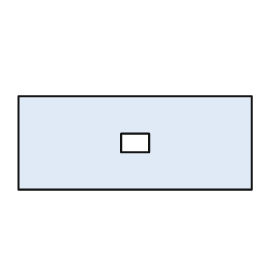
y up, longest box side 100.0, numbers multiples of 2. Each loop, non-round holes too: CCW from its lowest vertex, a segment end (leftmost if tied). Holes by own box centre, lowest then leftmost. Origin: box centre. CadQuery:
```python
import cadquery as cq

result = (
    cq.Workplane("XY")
    .moveTo(-50.0, -20.0)
    .lineTo(50.0, -20.0)
    .lineTo(50.0, 20.0)
    .lineTo(-50.0, 20.0)
    .close()
    .moveTo(-6.0, -4.0)
    .lineTo(6.0, -4.0)
    .lineTo(6.0, 4.0)
    .lineTo(-6.0, 4.0)
    .close()
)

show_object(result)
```